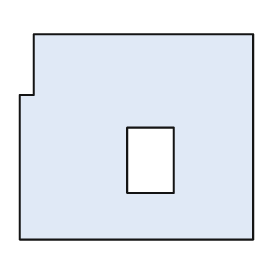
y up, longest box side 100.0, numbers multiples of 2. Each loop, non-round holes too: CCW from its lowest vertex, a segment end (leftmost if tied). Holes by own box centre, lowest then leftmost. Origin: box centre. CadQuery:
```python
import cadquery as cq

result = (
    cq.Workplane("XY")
    .moveTo(-50.0, -44.0)
    .lineTo(50.0, -44.0)
    .lineTo(50.0, 44.0)
    .lineTo(-44.0, 44.0)
    .lineTo(-44.0, 18.0)
    .lineTo(-50.0, 18.0)
    .close()
    .moveTo(-4.0, -24.0)
    .lineTo(16.0, -24.0)
    .lineTo(16.0, 4.0)
    .lineTo(-4.0, 4.0)
    .close()
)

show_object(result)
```